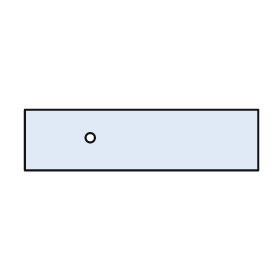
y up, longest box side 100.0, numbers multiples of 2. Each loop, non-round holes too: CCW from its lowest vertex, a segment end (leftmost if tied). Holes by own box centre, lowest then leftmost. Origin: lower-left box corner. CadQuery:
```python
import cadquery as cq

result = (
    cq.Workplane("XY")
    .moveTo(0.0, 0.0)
    .lineTo(100.0, 0.0)
    .lineTo(100.0, 26.0)
    .lineTo(0.0, 26.0)
    .close()
    .moveTo(28.0, 14.0)
    .circle(2.0)
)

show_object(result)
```